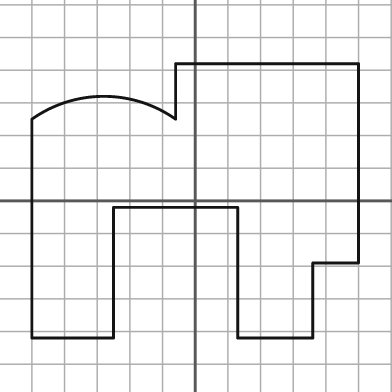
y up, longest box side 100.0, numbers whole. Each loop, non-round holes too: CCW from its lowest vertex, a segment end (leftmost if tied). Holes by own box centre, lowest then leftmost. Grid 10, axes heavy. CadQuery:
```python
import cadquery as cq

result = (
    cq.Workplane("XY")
    .moveTo(-50.0, -42.0)
    .lineTo(-25.0, -42.0)
    .lineTo(-25.0, -2.0)
    .lineTo(13.0, -2.0)
    .lineTo(13.0, -42.0)
    .lineTo(36.0, -42.0)
    .lineTo(36.0, -19.0)
    .lineTo(50.0, -19.0)
    .lineTo(50.0, 42.0)
    .lineTo(-6.0, 42.0)
    .lineTo(-6.0, 25.0)
    .threePointArc((-28.0, 32.0), (-50.0, 25.0))
    .close()
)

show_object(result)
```